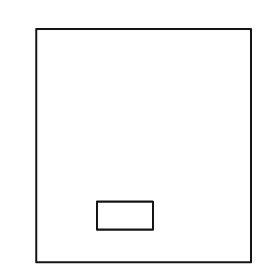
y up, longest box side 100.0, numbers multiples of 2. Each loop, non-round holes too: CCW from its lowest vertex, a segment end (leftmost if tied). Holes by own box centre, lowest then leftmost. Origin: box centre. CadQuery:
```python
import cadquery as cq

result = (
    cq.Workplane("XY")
    .moveTo(-46.0, -50.0)
    .lineTo(46.0, -50.0)
    .lineTo(46.0, 50.0)
    .lineTo(-46.0, 50.0)
    .close()
    .moveTo(-20.0, -36.0)
    .lineTo(4.0, -36.0)
    .lineTo(4.0, -24.0)
    .lineTo(-20.0, -24.0)
    .close()
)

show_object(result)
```